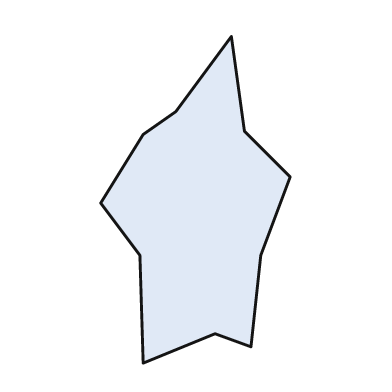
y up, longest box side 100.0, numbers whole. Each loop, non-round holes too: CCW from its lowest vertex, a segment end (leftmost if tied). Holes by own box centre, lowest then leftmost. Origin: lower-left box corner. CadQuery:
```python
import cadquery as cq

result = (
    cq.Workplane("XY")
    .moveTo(13.0, 0.0)
    .lineTo(35.0, 9.0)
    .lineTo(46.0, 5.0)
    .lineTo(49.0, 33.0)
    .lineTo(58.0, 57.0)
    .lineTo(44.0, 71.0)
    .lineTo(40.0, 100.0)
    .lineTo(23.0, 77.0)
    .lineTo(13.0, 70.0)
    .lineTo(0.0, 49.0)
    .lineTo(12.0, 33.0)
    .close()
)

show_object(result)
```